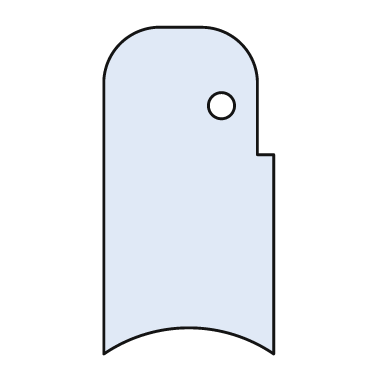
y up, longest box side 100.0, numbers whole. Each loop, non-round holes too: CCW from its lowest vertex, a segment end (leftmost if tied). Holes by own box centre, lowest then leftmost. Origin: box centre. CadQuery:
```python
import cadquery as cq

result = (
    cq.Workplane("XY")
    .moveTo(-26.0, -50.0)
    .threePointArc((0.0, -42.0), (26.0, -50.0))
    .lineTo(26.0, 11.0)
    .lineTo(21.0, 11.0)
    .lineTo(21.0, 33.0)
    .threePointArc((16.0, 45.0), (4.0, 50.0))
    .lineTo(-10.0, 50.0)
    .threePointArc((-21.0, 45.0), (-26.0, 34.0))
    .close()
    .moveTo(10.0, 26.0)
    .circle(4.0)
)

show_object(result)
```